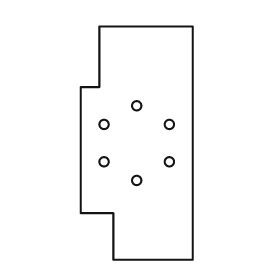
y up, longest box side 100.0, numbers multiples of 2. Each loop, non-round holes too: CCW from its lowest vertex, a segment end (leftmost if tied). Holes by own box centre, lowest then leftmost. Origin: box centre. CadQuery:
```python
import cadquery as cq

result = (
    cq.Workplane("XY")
    .moveTo(-10.0, -50.0)
    .lineTo(24.0, -50.0)
    .lineTo(24.0, 50.0)
    .lineTo(-16.0, 50.0)
    .lineTo(-16.0, 24.0)
    .lineTo(-24.0, 24.0)
    .lineTo(-24.0, -30.0)
    .lineTo(-10.0, -30.0)
    .close()
    .moveTo(0.0, -16.0)
    .circle(2.0)
    .moveTo(-14.0, -8.0)
    .circle(2.0)
    .moveTo(14.0, -8.0)
    .circle(2.0)
    .moveTo(-14.0, 8.0)
    .circle(2.0)
    .moveTo(14.0, 8.0)
    .circle(2.0)
    .moveTo(0.0, 16.0)
    .circle(2.0)
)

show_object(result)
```